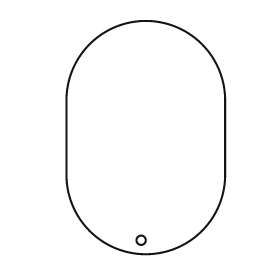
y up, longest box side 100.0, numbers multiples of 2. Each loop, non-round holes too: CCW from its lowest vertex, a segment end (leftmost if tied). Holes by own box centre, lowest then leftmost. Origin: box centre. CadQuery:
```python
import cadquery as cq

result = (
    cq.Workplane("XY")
    .moveTo(-34.0, -16.0)
    .threePointArc((0.0, -50.0), (34.0, -16.0))
    .lineTo(34.0, 16.0)
    .threePointArc((0.0, 50.0), (-34.0, 16.0))
    .close()
    .moveTo(-2.0, -44.0)
    .circle(2.0)
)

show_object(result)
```